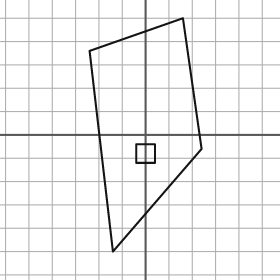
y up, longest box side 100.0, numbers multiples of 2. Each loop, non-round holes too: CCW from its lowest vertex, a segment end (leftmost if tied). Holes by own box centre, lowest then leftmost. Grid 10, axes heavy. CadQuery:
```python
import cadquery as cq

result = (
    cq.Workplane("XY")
    .moveTo(-14.0, -50.0)
    .lineTo(24.0, -6.0)
    .lineTo(16.0, 50.0)
    .lineTo(-24.0, 36.0)
    .close()
    .moveTo(-4.0, -12.0)
    .lineTo(4.0, -12.0)
    .lineTo(4.0, -4.0)
    .lineTo(-4.0, -4.0)
    .close()
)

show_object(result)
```